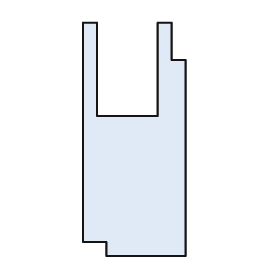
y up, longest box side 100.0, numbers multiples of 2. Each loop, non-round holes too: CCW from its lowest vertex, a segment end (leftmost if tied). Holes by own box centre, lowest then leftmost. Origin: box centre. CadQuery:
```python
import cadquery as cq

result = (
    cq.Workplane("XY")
    .moveTo(-12.0, -50.0)
    .lineTo(22.0, -50.0)
    .lineTo(22.0, 34.0)
    .lineTo(16.0, 34.0)
    .lineTo(16.0, 50.0)
    .lineTo(10.0, 50.0)
    .lineTo(10.0, 10.0)
    .lineTo(-16.0, 10.0)
    .lineTo(-16.0, 50.0)
    .lineTo(-22.0, 50.0)
    .lineTo(-22.0, -44.0)
    .lineTo(-12.0, -44.0)
    .close()
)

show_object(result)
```